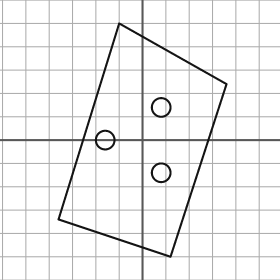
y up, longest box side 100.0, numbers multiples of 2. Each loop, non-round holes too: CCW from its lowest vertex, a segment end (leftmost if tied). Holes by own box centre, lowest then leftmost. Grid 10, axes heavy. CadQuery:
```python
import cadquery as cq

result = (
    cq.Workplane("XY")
    .moveTo(12.0, -50.0)
    .lineTo(36.0, 24.0)
    .lineTo(-10.0, 50.0)
    .lineTo(-36.0, -34.0)
    .close()
    .moveTo(8.0, -14.0)
    .circle(4.0)
    .moveTo(-16.0, 0.0)
    .circle(4.0)
    .moveTo(8.0, 14.0)
    .circle(4.0)
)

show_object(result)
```